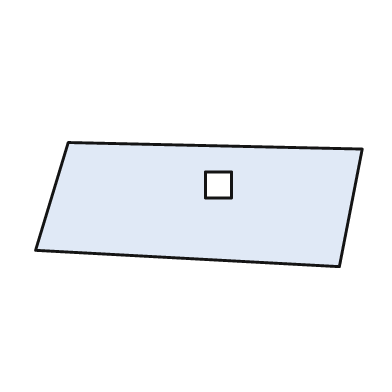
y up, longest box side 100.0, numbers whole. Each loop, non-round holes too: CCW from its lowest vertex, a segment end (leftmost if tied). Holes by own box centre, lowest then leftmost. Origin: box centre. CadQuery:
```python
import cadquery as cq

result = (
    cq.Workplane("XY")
    .moveTo(43.0, -19.0)
    .lineTo(50.0, 17.0)
    .lineTo(-40.0, 19.0)
    .lineTo(-50.0, -14.0)
    .close()
    .moveTo(2.0, 2.0)
    .lineTo(10.0, 2.0)
    .lineTo(10.0, 10.0)
    .lineTo(2.0, 10.0)
    .close()
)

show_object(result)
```